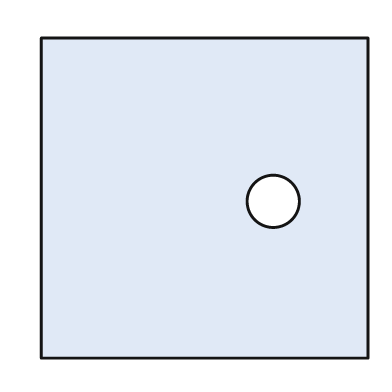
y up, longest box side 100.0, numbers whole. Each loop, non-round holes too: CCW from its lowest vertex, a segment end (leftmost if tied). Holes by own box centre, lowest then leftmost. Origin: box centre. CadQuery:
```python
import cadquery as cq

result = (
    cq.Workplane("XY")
    .moveTo(-50.0, -49.0)
    .lineTo(50.0, -49.0)
    .lineTo(50.0, 49.0)
    .lineTo(-50.0, 49.0)
    .close()
    .moveTo(21.0, -1.0)
    .circle(8.0)
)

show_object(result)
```